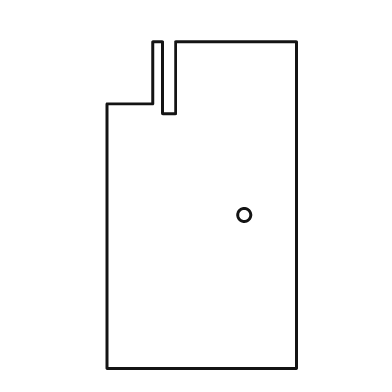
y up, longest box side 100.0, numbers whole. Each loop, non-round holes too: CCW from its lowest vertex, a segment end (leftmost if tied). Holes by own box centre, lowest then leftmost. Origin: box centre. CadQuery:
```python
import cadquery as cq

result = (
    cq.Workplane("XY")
    .moveTo(-29.0, -50.0)
    .lineTo(29.0, -50.0)
    .lineTo(29.0, 50.0)
    .lineTo(-8.0, 50.0)
    .lineTo(-8.0, 28.0)
    .lineTo(-12.0, 28.0)
    .lineTo(-12.0, 50.0)
    .lineTo(-15.0, 50.0)
    .lineTo(-15.0, 31.0)
    .lineTo(-29.0, 31.0)
    .close()
    .moveTo(13.0, -3.0)
    .circle(2.0)
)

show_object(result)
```